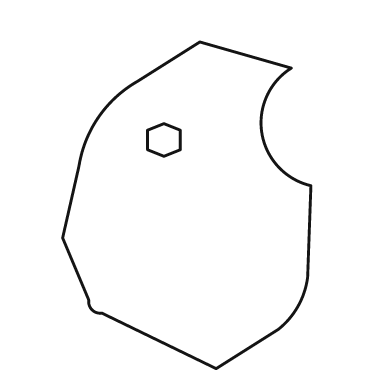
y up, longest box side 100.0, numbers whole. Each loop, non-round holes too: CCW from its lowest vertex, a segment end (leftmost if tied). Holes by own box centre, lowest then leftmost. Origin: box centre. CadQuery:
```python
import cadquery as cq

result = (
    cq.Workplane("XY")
    .moveTo(9.0, -50.0)
    .lineTo(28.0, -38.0)
    .threePointArc((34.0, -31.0), (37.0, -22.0))
    .lineTo(38.0, 6.0)
    .threePointArc((23.0, 22.0), (32.0, 42.0))
    .lineTo(4.0, 50.0)
    .lineTo(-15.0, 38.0)
    .threePointArc((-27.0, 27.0), (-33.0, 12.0))
    .lineTo(-38.0, -10.0)
    .lineTo(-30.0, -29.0)
    .threePointArc((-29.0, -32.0), (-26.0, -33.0))
    .close()
    .moveTo(-7.0, 15.0)
    .lineTo(-2.0, 17.0)
    .lineTo(-2.0, 23.0)
    .lineTo(-7.0, 25.0)
    .lineTo(-12.0, 23.0)
    .lineTo(-12.0, 17.0)
    .close()
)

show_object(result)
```